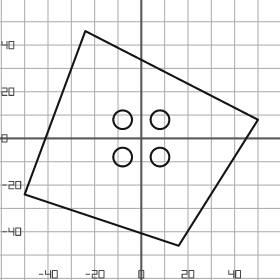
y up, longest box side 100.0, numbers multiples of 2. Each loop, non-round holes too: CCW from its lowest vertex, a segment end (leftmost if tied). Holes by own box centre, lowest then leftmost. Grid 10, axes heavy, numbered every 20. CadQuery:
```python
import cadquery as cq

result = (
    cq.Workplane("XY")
    .moveTo(16.0, -46.0)
    .lineTo(50.0, 8.0)
    .lineTo(-24.0, 46.0)
    .lineTo(-50.0, -24.0)
    .close()
    .moveTo(-8.0, -8.0)
    .circle(4.0)
    .moveTo(8.0, -8.0)
    .circle(4.0)
    .moveTo(-8.0, 8.0)
    .circle(4.0)
    .moveTo(8.0, 8.0)
    .circle(4.0)
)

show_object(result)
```